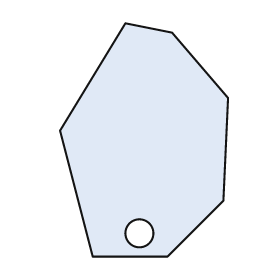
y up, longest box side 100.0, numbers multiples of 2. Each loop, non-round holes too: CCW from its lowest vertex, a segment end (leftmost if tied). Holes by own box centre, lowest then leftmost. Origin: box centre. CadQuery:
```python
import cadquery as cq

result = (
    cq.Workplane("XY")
    .moveTo(-22.0, -50.0)
    .lineTo(10.0, -50.0)
    .lineTo(34.0, -26.0)
    .lineTo(36.0, 18.0)
    .lineTo(12.0, 46.0)
    .lineTo(-8.0, 50.0)
    .lineTo(-36.0, 4.0)
    .close()
    .moveTo(-2.0, -40.0)
    .circle(6.0)
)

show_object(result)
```